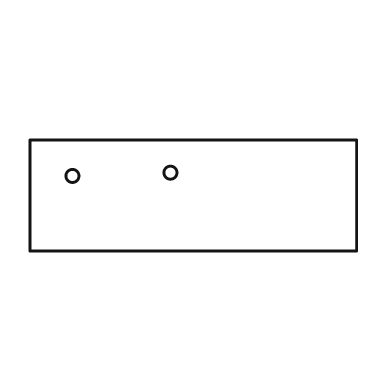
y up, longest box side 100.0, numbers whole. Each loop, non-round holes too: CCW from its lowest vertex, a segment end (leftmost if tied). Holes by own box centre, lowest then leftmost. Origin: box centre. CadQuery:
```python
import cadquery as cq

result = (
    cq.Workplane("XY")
    .moveTo(-50.0, -17.0)
    .lineTo(50.0, -17.0)
    .lineTo(50.0, 17.0)
    .lineTo(-50.0, 17.0)
    .close()
    .moveTo(-37.0, 6.0)
    .circle(2.0)
    .moveTo(-7.0, 7.0)
    .circle(2.0)
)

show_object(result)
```